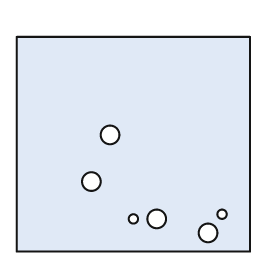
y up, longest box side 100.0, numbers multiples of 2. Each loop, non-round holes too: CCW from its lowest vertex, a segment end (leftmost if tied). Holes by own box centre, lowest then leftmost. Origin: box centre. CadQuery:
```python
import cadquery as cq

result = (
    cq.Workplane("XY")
    .moveTo(-50.0, -46.0)
    .lineTo(50.0, -46.0)
    .lineTo(50.0, 46.0)
    .lineTo(-50.0, 46.0)
    .close()
    .moveTo(32.0, -38.0)
    .circle(4.0)
    .moveTo(0.0, -32.0)
    .circle(2.0)
    .moveTo(10.0, -32.0)
    .circle(4.0)
    .moveTo(38.0, -30.0)
    .circle(2.0)
    .moveTo(-18.0, -16.0)
    .circle(4.0)
    .moveTo(-10.0, 4.0)
    .circle(4.0)
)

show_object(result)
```